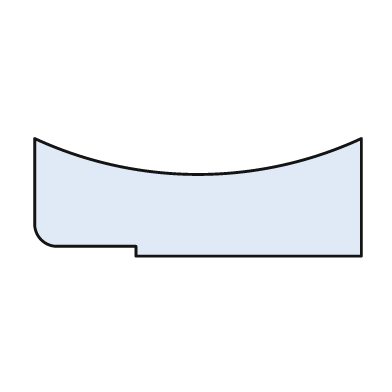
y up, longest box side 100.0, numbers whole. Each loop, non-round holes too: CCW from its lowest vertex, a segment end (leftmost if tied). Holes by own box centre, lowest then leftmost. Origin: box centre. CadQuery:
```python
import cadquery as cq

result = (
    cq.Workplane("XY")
    .moveTo(-19.0, -18.0)
    .lineTo(50.0, -18.0)
    .lineTo(50.0, 18.0)
    .threePointArc((0.0, 7.0), (-50.0, 18.0))
    .lineTo(-50.0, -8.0)
    .threePointArc((-48.0, -13.0), (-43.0, -15.0))
    .lineTo(-19.0, -15.0)
    .close()
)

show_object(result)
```